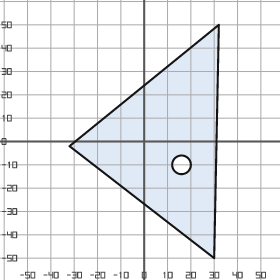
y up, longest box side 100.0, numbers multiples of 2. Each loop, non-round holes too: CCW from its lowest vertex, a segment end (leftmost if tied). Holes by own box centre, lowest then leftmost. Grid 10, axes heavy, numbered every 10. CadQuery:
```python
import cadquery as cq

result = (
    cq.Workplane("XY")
    .moveTo(30.0, -50.0)
    .lineTo(32.0, 50.0)
    .lineTo(-32.0, -2.0)
    .close()
    .moveTo(16.0, -10.0)
    .circle(4.0)
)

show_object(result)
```